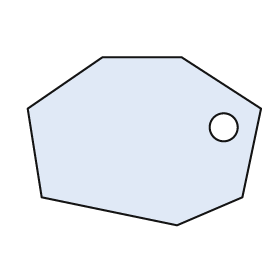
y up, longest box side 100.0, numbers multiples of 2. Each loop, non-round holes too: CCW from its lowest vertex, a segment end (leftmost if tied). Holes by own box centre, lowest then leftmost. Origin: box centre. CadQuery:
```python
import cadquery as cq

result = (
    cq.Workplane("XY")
    .moveTo(14.0, -36.0)
    .lineTo(42.0, -24.0)
    .lineTo(50.0, 14.0)
    .lineTo(16.0, 36.0)
    .lineTo(-18.0, 36.0)
    .lineTo(-50.0, 14.0)
    .lineTo(-44.0, -24.0)
    .close()
    .moveTo(34.0, 6.0)
    .circle(6.0)
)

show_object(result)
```